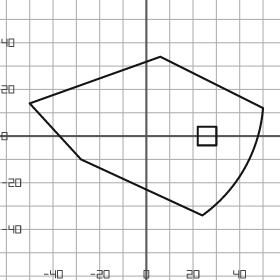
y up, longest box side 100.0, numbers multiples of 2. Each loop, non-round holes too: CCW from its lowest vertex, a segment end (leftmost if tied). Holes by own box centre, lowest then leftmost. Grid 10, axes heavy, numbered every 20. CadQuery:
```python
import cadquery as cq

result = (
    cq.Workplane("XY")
    .moveTo(24.0, -34.0)
    .threePointArc((42.0, -14.0), (50.0, 12.0))
    .lineTo(6.0, 34.0)
    .lineTo(-50.0, 14.0)
    .lineTo(-28.0, -10.0)
    .close()
    .moveTo(22.0, -4.0)
    .lineTo(30.0, -4.0)
    .lineTo(30.0, 4.0)
    .lineTo(22.0, 4.0)
    .close()
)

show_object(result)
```